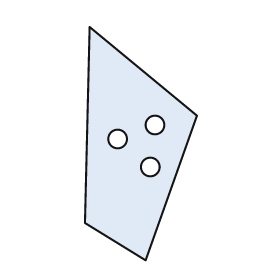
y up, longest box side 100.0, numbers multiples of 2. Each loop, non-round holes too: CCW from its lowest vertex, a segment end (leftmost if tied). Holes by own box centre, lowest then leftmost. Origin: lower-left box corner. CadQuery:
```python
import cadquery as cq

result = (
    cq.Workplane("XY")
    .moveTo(26.0, 0.0)
    .lineTo(48.0, 62.0)
    .lineTo(2.0, 100.0)
    .lineTo(0.0, 16.0)
    .close()
    .moveTo(28.0, 40.0)
    .circle(4.0)
    .moveTo(14.0, 52.0)
    .circle(4.0)
    .moveTo(30.0, 58.0)
    .circle(4.0)
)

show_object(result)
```